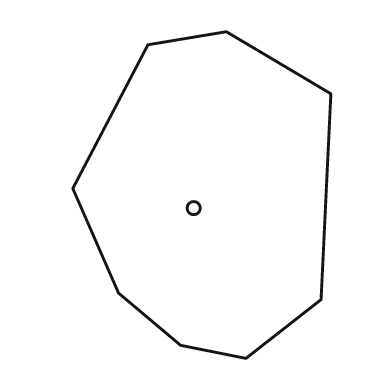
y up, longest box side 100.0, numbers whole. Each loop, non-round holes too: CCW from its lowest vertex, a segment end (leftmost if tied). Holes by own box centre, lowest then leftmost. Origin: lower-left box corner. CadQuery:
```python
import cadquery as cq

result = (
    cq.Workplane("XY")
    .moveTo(53.0, 0.0)
    .lineTo(76.0, 18.0)
    .lineTo(79.0, 81.0)
    .lineTo(47.0, 100.0)
    .lineTo(23.0, 96.0)
    .lineTo(0.0, 52.0)
    .lineTo(14.0, 20.0)
    .lineTo(33.0, 4.0)
    .close()
    .moveTo(37.0, 46.0)
    .circle(2.0)
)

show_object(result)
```